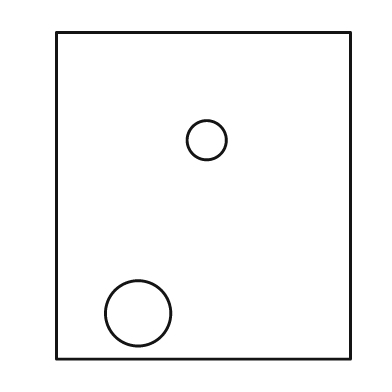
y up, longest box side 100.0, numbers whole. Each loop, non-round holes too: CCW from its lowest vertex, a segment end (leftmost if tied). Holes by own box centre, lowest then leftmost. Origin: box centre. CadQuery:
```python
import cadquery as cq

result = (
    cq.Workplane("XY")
    .moveTo(-45.0, -50.0)
    .lineTo(45.0, -50.0)
    .lineTo(45.0, 50.0)
    .lineTo(-45.0, 50.0)
    .close()
    .moveTo(-20.0, -36.0)
    .circle(10.0)
    .moveTo(1.0, 17.0)
    .circle(6.0)
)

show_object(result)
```